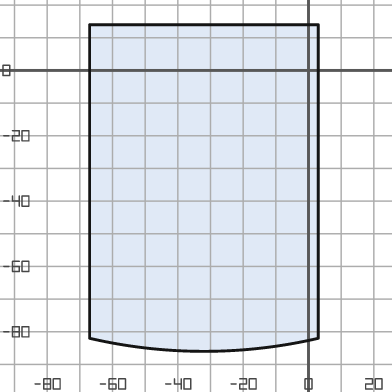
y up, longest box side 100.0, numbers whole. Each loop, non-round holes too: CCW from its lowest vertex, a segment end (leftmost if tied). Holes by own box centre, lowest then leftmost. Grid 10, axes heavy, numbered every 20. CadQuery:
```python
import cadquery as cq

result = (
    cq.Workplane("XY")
    .moveTo(-67.0, -82.0)
    .threePointArc((-32.0, -86.0), (3.0, -82.0))
    .lineTo(3.0, 14.0)
    .lineTo(-67.0, 14.0)
    .close()
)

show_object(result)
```